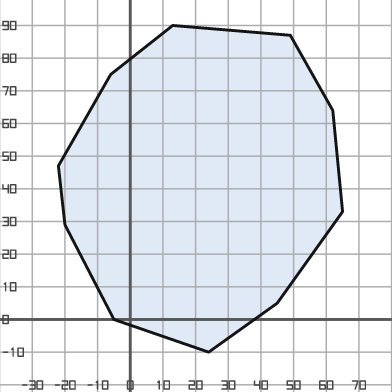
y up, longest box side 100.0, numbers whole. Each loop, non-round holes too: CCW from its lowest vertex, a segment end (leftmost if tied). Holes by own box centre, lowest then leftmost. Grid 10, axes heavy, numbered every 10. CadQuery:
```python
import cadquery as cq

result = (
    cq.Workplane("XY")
    .moveTo(24.0, -10.0)
    .lineTo(45.0, 5.0)
    .lineTo(65.0, 33.0)
    .lineTo(62.0, 64.0)
    .lineTo(49.0, 87.0)
    .lineTo(13.0, 90.0)
    .lineTo(-6.0, 75.0)
    .lineTo(-22.0, 47.0)
    .lineTo(-20.0, 29.0)
    .lineTo(-5.0, 0.0)
    .close()
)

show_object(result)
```